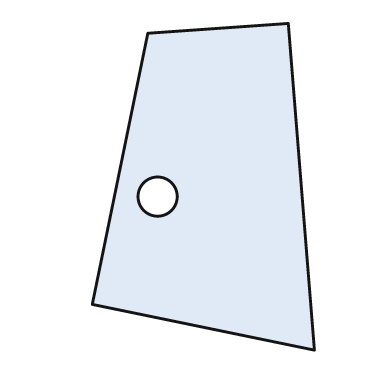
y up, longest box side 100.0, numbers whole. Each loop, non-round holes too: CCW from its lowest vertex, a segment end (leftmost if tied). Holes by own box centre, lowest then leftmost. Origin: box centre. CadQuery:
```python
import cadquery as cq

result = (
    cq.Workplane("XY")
    .moveTo(34.0, -50.0)
    .lineTo(26.0, 50.0)
    .lineTo(-17.0, 47.0)
    .lineTo(-34.0, -36.0)
    .close()
    .moveTo(-14.0, -3.0)
    .circle(6.0)
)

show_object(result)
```